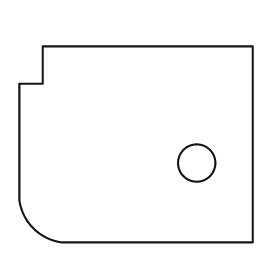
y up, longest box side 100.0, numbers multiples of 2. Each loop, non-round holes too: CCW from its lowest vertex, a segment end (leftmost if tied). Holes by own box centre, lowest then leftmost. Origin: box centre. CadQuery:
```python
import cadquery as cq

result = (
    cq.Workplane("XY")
    .moveTo(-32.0, -42.0)
    .lineTo(50.0, -42.0)
    .lineTo(50.0, 42.0)
    .lineTo(-40.0, 42.0)
    .lineTo(-40.0, 26.0)
    .lineTo(-50.0, 26.0)
    .lineTo(-50.0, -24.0)
    .threePointArc((-44.0, -36.0), (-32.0, -42.0))
    .close()
    .moveTo(26.0, -8.0)
    .circle(8.0)
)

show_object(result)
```